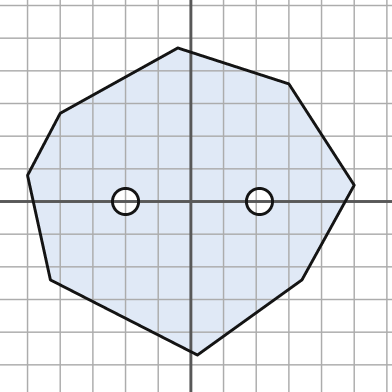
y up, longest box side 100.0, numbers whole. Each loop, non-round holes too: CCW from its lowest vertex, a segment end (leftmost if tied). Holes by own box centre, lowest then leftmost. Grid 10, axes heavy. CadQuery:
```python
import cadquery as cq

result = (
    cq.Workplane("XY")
    .moveTo(2.0, -47.0)
    .lineTo(34.0, -24.0)
    .lineTo(50.0, 5.0)
    .lineTo(30.0, 36.0)
    .lineTo(-4.0, 47.0)
    .lineTo(-40.0, 27.0)
    .lineTo(-50.0, 8.0)
    .lineTo(-43.0, -24.0)
    .close()
    .moveTo(-20.0, 0.0)
    .circle(4.0)
    .moveTo(21.0, 0.0)
    .circle(4.0)
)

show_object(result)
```